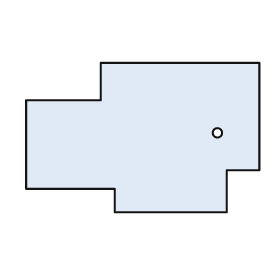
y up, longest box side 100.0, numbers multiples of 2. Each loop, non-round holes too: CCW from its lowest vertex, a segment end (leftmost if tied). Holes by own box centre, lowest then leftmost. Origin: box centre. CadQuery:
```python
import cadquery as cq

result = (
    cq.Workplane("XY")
    .moveTo(-12.0, -32.0)
    .lineTo(36.0, -32.0)
    .lineTo(36.0, -14.0)
    .lineTo(50.0, -14.0)
    .lineTo(50.0, 32.0)
    .lineTo(-18.0, 32.0)
    .lineTo(-18.0, 16.0)
    .lineTo(-50.0, 16.0)
    .lineTo(-50.0, -22.0)
    .lineTo(-12.0, -22.0)
    .close()
    .moveTo(32.0, 2.0)
    .circle(2.0)
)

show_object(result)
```